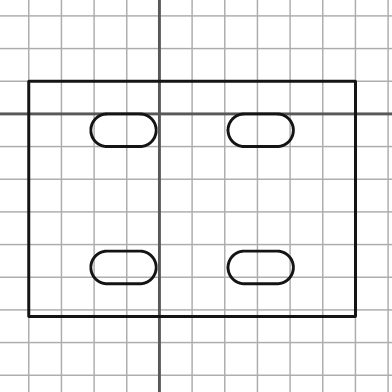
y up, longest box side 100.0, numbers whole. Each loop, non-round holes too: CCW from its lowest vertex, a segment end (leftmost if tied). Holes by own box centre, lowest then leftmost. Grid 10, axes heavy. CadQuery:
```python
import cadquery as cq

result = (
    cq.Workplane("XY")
    .moveTo(-40.0, -62.0)
    .lineTo(60.0, -62.0)
    .lineTo(60.0, 10.0)
    .lineTo(-40.0, 10.0)
    .close()
    .moveTo(-16.0, -52.0)
    .lineTo(-6.0, -52.0)
    .threePointArc((-1.0, -47.0), (-6.0, -42.0))
    .lineTo(-16.0, -42.0)
    .threePointArc((-21.0, -47.0), (-16.0, -52.0))
    .close()
    .moveTo(26.0, -52.0)
    .lineTo(36.0, -52.0)
    .threePointArc((41.0, -47.0), (36.0, -42.0))
    .lineTo(26.0, -42.0)
    .threePointArc((21.0, -47.0), (26.0, -52.0))
    .close()
    .moveTo(-16.0, -10.0)
    .lineTo(-6.0, -10.0)
    .threePointArc((-1.0, -5.0), (-6.0, 0.0))
    .lineTo(-16.0, 0.0)
    .threePointArc((-21.0, -5.0), (-16.0, -10.0))
    .close()
    .moveTo(26.0, -10.0)
    .lineTo(36.0, -10.0)
    .threePointArc((41.0, -5.0), (36.0, 0.0))
    .lineTo(26.0, 0.0)
    .threePointArc((21.0, -5.0), (26.0, -10.0))
    .close()
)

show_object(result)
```